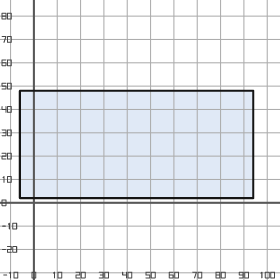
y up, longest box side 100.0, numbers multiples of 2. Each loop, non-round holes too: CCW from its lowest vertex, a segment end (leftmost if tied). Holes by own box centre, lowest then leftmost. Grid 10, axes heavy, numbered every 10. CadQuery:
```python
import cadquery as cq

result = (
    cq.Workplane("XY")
    .moveTo(-6.0, 2.0)
    .lineTo(94.0, 2.0)
    .lineTo(94.0, 48.0)
    .lineTo(-6.0, 48.0)
    .close()
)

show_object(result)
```